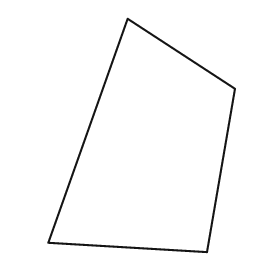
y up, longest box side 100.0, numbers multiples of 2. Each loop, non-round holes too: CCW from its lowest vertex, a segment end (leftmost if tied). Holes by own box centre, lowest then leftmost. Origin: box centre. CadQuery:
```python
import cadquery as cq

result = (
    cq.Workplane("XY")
    .moveTo(28.0, -50.0)
    .lineTo(40.0, 20.0)
    .lineTo(-6.0, 50.0)
    .lineTo(-40.0, -46.0)
    .close()
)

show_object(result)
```